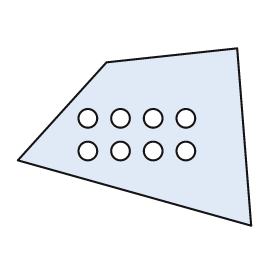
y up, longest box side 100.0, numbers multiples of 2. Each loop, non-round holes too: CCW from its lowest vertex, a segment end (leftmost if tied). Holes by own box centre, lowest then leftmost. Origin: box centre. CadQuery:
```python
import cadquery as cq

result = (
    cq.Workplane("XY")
    .moveTo(50.0, -38.0)
    .lineTo(44.0, 38.0)
    .lineTo(-12.0, 32.0)
    .lineTo(-50.0, -10.0)
    .close()
    .moveTo(-20.0, -6.0)
    .circle(4.0)
    .moveTo(-6.0, -6.0)
    .circle(4.0)
    .moveTo(8.0, -6.0)
    .circle(4.0)
    .moveTo(22.0, -6.0)
    .circle(4.0)
    .moveTo(-20.0, 8.0)
    .circle(4.0)
    .moveTo(-6.0, 8.0)
    .circle(4.0)
    .moveTo(8.0, 8.0)
    .circle(4.0)
    .moveTo(22.0, 8.0)
    .circle(4.0)
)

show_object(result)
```